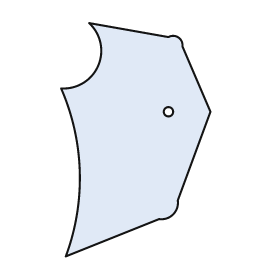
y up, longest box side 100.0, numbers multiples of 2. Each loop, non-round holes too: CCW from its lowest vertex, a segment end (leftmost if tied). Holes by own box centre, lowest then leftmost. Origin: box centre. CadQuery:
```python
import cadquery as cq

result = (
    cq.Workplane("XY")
    .moveTo(-30.0, -50.0)
    .lineTo(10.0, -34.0)
    .threePointArc((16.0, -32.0), (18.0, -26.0))
    .lineTo(32.0, 12.0)
    .lineTo(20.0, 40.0)
    .threePointArc((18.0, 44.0), (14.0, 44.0))
    .lineTo(-20.0, 50.0)
    .threePointArc((-16.0, 32.0), (-32.0, 22.0))
    .threePointArc((-24.0, -14.0), (-30.0, -50.0))
    .close()
    .moveTo(14.0, 12.0)
    .circle(2.0)
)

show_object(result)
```